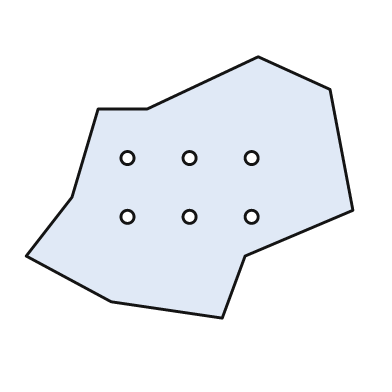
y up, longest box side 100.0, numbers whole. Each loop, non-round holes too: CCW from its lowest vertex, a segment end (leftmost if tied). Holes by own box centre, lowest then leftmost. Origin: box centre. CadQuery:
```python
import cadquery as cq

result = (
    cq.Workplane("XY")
    .moveTo(10.0, -40.0)
    .lineTo(17.0, -21.0)
    .lineTo(50.0, -7.0)
    .lineTo(43.0, 30.0)
    .lineTo(21.0, 40.0)
    .lineTo(-13.0, 24.0)
    .lineTo(-28.0, 24.0)
    .lineTo(-36.0, -3.0)
    .lineTo(-50.0, -21.0)
    .lineTo(-24.0, -35.0)
    .close()
    .moveTo(-19.0, -9.0)
    .circle(2.0)
    .moveTo(0.0, -9.0)
    .circle(2.0)
    .moveTo(19.0, -9.0)
    .circle(2.0)
    .moveTo(-19.0, 9.0)
    .circle(2.0)
    .moveTo(0.0, 9.0)
    .circle(2.0)
    .moveTo(19.0, 9.0)
    .circle(2.0)
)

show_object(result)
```